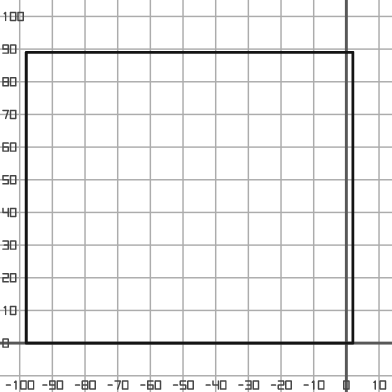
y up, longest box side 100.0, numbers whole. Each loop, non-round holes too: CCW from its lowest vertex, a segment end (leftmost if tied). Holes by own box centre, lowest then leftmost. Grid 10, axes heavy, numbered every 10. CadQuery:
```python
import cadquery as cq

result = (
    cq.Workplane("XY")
    .moveTo(-98.0, 0.0)
    .lineTo(2.0, 0.0)
    .lineTo(2.0, 89.0)
    .lineTo(-98.0, 89.0)
    .close()
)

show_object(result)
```